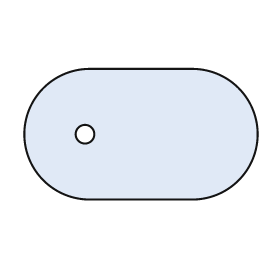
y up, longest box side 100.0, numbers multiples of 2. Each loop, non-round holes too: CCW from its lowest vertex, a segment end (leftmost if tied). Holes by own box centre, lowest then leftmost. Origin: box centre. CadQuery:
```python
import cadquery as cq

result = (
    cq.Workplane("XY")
    .moveTo(-22.0, -28.0)
    .lineTo(22.0, -28.0)
    .threePointArc((50.0, 0.0), (22.0, 28.0))
    .lineTo(-22.0, 28.0)
    .threePointArc((-50.0, 0.0), (-22.0, -28.0))
    .close()
    .moveTo(-24.0, 0.0)
    .circle(4.0)
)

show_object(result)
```